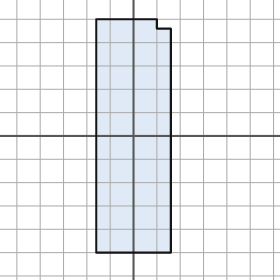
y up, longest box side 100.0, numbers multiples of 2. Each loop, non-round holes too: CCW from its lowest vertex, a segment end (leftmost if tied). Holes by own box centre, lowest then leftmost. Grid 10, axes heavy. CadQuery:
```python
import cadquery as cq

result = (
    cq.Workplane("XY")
    .moveTo(-16.0, -50.0)
    .lineTo(16.0, -50.0)
    .lineTo(16.0, 46.0)
    .lineTo(10.0, 46.0)
    .lineTo(10.0, 50.0)
    .lineTo(-16.0, 50.0)
    .close()
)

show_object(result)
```